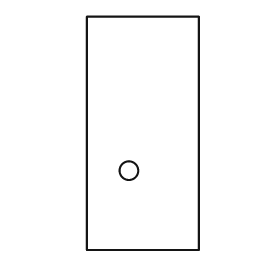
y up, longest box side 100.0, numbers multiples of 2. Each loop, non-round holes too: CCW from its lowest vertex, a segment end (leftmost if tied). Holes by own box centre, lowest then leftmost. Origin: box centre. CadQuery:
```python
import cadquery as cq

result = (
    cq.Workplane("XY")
    .moveTo(-24.0, -50.0)
    .lineTo(24.0, -50.0)
    .lineTo(24.0, 50.0)
    .lineTo(-24.0, 50.0)
    .close()
    .moveTo(-6.0, -16.0)
    .circle(4.0)
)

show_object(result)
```